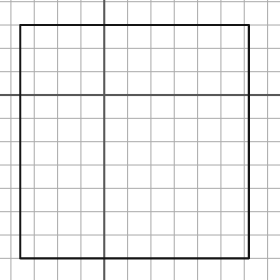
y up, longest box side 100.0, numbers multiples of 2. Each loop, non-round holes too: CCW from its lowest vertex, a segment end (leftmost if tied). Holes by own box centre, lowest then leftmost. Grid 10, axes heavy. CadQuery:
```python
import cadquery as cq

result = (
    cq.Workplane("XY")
    .moveTo(-36.0, -70.0)
    .lineTo(62.0, -70.0)
    .lineTo(62.0, 30.0)
    .lineTo(-36.0, 30.0)
    .close()
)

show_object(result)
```